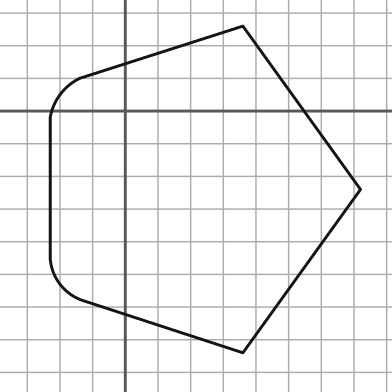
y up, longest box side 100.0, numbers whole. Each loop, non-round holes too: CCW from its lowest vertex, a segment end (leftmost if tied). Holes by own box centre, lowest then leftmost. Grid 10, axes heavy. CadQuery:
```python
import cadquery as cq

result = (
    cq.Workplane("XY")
    .moveTo(36.0, -74.0)
    .lineTo(72.0, -24.0)
    .lineTo(36.0, 26.0)
    .lineTo(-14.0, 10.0)
    .threePointArc((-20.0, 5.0), (-23.0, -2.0))
    .lineTo(-23.0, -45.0)
    .threePointArc((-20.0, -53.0), (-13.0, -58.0))
    .close()
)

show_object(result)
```